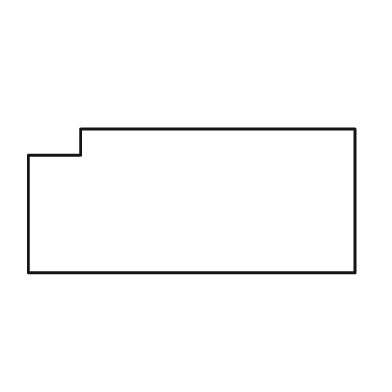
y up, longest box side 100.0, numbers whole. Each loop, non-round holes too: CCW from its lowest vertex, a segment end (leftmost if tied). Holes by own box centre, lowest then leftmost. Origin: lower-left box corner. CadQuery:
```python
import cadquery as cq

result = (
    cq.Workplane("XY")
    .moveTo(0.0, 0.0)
    .lineTo(100.0, 0.0)
    .lineTo(100.0, 44.0)
    .lineTo(16.0, 44.0)
    .lineTo(16.0, 36.0)
    .lineTo(0.0, 36.0)
    .close()
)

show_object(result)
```